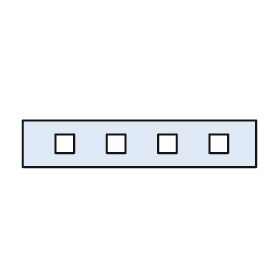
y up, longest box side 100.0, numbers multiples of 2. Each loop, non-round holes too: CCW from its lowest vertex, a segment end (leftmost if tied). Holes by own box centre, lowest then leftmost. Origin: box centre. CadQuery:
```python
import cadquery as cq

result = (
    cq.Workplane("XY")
    .moveTo(-50.0, -10.0)
    .lineTo(50.0, -10.0)
    .lineTo(50.0, 10.0)
    .lineTo(-50.0, 10.0)
    .close()
    .moveTo(-36.0, -4.0)
    .lineTo(-28.0, -4.0)
    .lineTo(-28.0, 4.0)
    .lineTo(-36.0, 4.0)
    .close()
    .moveTo(-14.0, -4.0)
    .lineTo(-6.0, -4.0)
    .lineTo(-6.0, 4.0)
    .lineTo(-14.0, 4.0)
    .close()
    .moveTo(8.0, -4.0)
    .lineTo(16.0, -4.0)
    .lineTo(16.0, 4.0)
    .lineTo(8.0, 4.0)
    .close()
    .moveTo(30.0, -4.0)
    .lineTo(38.0, -4.0)
    .lineTo(38.0, 4.0)
    .lineTo(30.0, 4.0)
    .close()
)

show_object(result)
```